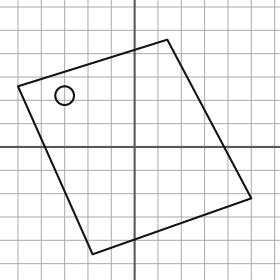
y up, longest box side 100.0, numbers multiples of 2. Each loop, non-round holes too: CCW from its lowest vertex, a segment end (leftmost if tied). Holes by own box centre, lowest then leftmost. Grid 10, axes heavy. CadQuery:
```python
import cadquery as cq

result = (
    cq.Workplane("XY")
    .moveTo(-18.0, -46.0)
    .lineTo(50.0, -22.0)
    .lineTo(14.0, 46.0)
    .lineTo(-50.0, 26.0)
    .close()
    .moveTo(-30.0, 22.0)
    .circle(4.0)
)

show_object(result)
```